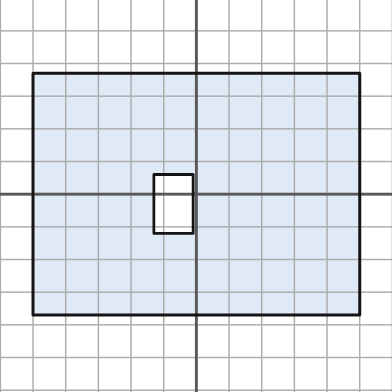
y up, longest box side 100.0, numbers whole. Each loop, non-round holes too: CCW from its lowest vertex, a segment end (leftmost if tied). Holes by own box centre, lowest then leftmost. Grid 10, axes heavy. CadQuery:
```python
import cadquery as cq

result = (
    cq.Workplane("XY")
    .moveTo(-50.0, -37.0)
    .lineTo(50.0, -37.0)
    .lineTo(50.0, 37.0)
    .lineTo(-50.0, 37.0)
    .close()
    .moveTo(-13.0, -12.0)
    .lineTo(-1.0, -12.0)
    .lineTo(-1.0, 6.0)
    .lineTo(-13.0, 6.0)
    .close()
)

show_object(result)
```